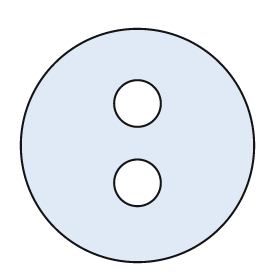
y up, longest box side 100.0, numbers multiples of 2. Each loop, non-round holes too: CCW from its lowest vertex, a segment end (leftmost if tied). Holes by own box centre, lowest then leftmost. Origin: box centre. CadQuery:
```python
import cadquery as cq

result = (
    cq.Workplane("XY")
    .moveTo(0.0, 0.0)
    .circle(50.0)
    .moveTo(0.0, -16.0)
    .circle(10.0)
    .moveTo(0.0, 18.0)
    .circle(10.0)
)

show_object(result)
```